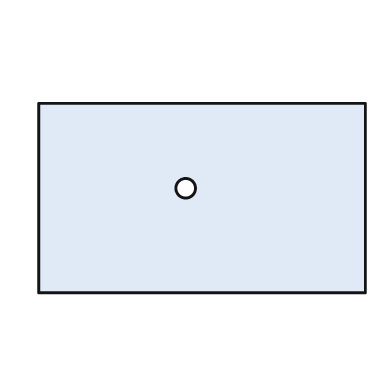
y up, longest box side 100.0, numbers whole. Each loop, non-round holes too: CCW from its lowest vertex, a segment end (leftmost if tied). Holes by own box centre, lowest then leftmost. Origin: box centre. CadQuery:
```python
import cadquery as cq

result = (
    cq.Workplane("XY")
    .moveTo(-50.0, -29.0)
    .lineTo(50.0, -29.0)
    .lineTo(50.0, 29.0)
    .lineTo(-50.0, 29.0)
    .close()
    .moveTo(-5.0, 3.0)
    .circle(3.0)
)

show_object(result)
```